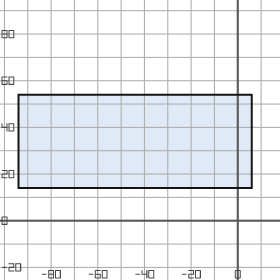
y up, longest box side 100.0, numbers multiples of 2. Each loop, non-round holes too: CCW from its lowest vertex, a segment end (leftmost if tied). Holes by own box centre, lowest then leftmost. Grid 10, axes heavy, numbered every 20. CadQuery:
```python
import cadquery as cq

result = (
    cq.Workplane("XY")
    .moveTo(-94.0, 14.0)
    .lineTo(6.0, 14.0)
    .lineTo(6.0, 54.0)
    .lineTo(-94.0, 54.0)
    .close()
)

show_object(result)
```